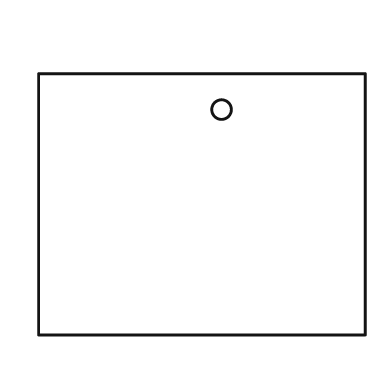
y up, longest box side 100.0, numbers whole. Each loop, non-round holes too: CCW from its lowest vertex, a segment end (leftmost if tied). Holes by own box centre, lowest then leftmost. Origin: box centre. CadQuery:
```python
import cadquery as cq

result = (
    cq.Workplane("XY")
    .moveTo(-50.0, -40.0)
    .lineTo(50.0, -40.0)
    .lineTo(50.0, 40.0)
    .lineTo(-50.0, 40.0)
    .close()
    .moveTo(6.0, 29.0)
    .circle(3.0)
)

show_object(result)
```